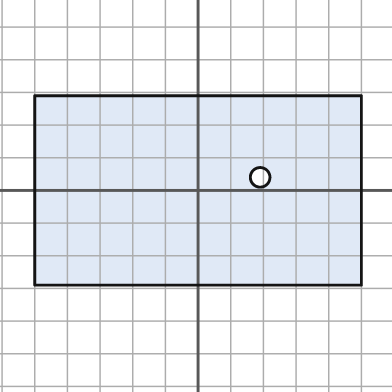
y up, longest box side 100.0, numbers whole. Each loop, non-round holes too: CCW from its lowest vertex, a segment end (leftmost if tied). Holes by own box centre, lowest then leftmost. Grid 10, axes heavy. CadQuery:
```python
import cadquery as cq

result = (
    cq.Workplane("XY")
    .moveTo(-50.0, -29.0)
    .lineTo(50.0, -29.0)
    .lineTo(50.0, 29.0)
    .lineTo(-50.0, 29.0)
    .close()
    .moveTo(19.0, 4.0)
    .circle(3.0)
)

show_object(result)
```